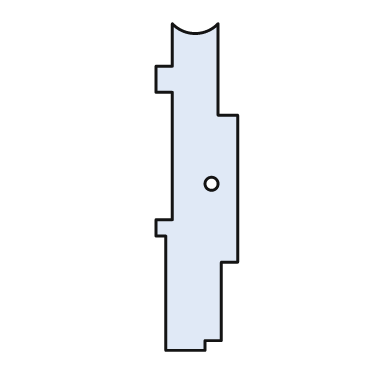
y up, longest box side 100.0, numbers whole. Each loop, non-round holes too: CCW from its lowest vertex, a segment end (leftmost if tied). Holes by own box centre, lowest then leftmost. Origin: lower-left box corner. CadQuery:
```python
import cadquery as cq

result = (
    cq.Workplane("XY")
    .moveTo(3.0, 0.0)
    .lineTo(15.0, 0.0)
    .lineTo(15.0, 3.0)
    .lineTo(20.0, 3.0)
    .lineTo(20.0, 27.0)
    .lineTo(25.0, 27.0)
    .lineTo(25.0, 72.0)
    .lineTo(19.0, 72.0)
    .lineTo(19.0, 100.0)
    .threePointArc((12.0, 97.0), (5.0, 100.0))
    .lineTo(5.0, 87.0)
    .lineTo(0.0, 87.0)
    .lineTo(0.0, 79.0)
    .lineTo(5.0, 79.0)
    .lineTo(5.0, 40.0)
    .lineTo(0.0, 40.0)
    .lineTo(0.0, 35.0)
    .lineTo(3.0, 35.0)
    .close()
    .moveTo(17.0, 51.0)
    .circle(2.0)
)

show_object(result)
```